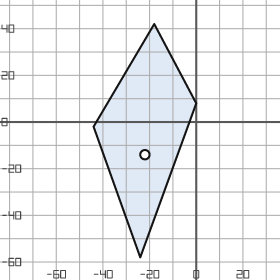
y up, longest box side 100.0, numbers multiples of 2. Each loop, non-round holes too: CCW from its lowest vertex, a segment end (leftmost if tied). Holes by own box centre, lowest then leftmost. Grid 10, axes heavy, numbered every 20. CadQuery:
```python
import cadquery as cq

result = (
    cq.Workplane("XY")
    .moveTo(-24.0, -58.0)
    .lineTo(0.0, 8.0)
    .lineTo(-18.0, 42.0)
    .lineTo(-44.0, -2.0)
    .close()
    .moveTo(-22.0, -14.0)
    .circle(2.0)
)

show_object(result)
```